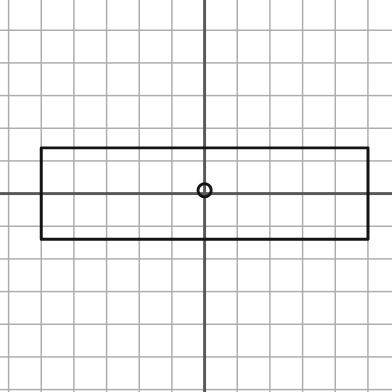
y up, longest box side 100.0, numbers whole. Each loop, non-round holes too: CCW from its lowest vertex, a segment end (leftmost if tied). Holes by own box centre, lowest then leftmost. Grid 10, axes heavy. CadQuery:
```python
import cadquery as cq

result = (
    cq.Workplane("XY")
    .moveTo(-50.0, -14.0)
    .lineTo(50.0, -14.0)
    .lineTo(50.0, 14.0)
    .lineTo(-50.0, 14.0)
    .close()
    .moveTo(0.0, 1.0)
    .circle(2.0)
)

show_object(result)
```